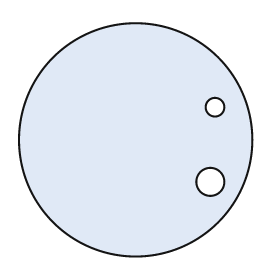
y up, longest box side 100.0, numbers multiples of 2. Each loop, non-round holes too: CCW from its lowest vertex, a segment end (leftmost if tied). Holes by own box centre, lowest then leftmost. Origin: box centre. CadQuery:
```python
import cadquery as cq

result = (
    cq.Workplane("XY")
    .moveTo(0.0, 0.0)
    .circle(50.0)
    .moveTo(32.0, -18.0)
    .circle(6.0)
    .moveTo(34.0, 14.0)
    .circle(4.0)
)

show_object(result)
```